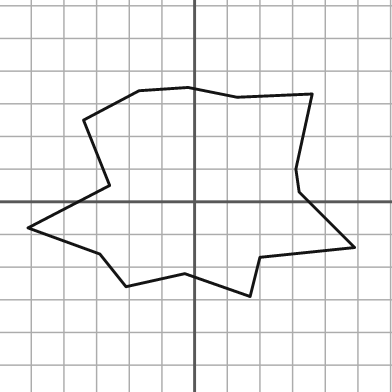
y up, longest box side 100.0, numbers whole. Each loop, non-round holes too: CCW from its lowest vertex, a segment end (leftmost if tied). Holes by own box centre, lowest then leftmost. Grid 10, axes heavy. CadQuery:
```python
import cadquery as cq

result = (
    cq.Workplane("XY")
    .moveTo(17.0, -29.0)
    .lineTo(20.0, -17.0)
    .lineTo(49.0, -14.0)
    .lineTo(32.0, 3.0)
    .lineTo(31.0, 10.0)
    .lineTo(36.0, 33.0)
    .lineTo(13.0, 32.0)
    .lineTo(-2.0, 35.0)
    .lineTo(-17.0, 34.0)
    .lineTo(-34.0, 25.0)
    .lineTo(-26.0, 5.0)
    .lineTo(-51.0, -8.0)
    .lineTo(-29.0, -16.0)
    .lineTo(-21.0, -26.0)
    .lineTo(-3.0, -22.0)
    .close()
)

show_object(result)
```